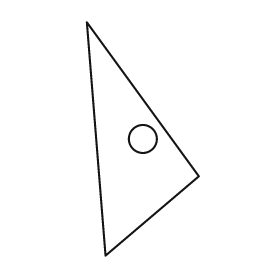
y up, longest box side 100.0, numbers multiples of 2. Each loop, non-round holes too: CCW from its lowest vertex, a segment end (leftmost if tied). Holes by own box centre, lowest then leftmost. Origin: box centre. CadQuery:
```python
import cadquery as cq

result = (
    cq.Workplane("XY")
    .moveTo(-16.0, -50.0)
    .lineTo(24.0, -16.0)
    .lineTo(-24.0, 50.0)
    .close()
    .moveTo(0.0, 0.0)
    .circle(6.0)
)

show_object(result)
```